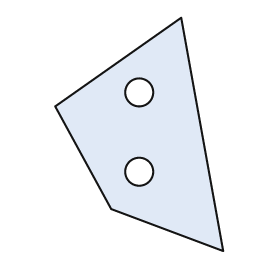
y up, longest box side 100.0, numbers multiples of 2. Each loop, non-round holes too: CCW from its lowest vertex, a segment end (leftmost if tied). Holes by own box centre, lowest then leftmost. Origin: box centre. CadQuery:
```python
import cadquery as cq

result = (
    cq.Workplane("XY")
    .moveTo(36.0, -50.0)
    .lineTo(18.0, 50.0)
    .lineTo(-36.0, 12.0)
    .lineTo(-12.0, -32.0)
    .close()
    .moveTo(0.0, -16.0)
    .circle(6.0)
    .moveTo(0.0, 18.0)
    .circle(6.0)
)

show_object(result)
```